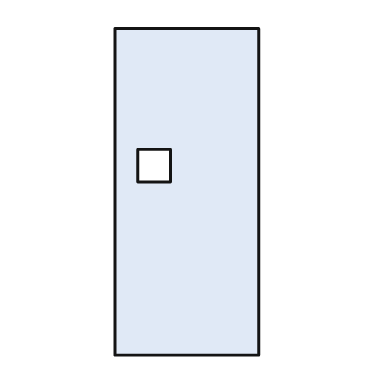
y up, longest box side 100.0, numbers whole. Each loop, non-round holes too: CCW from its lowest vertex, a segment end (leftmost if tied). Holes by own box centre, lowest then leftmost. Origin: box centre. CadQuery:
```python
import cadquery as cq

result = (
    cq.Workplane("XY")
    .moveTo(-22.0, -50.0)
    .lineTo(22.0, -50.0)
    .lineTo(22.0, 50.0)
    .lineTo(-22.0, 50.0)
    .close()
    .moveTo(-15.0, 3.0)
    .lineTo(-5.0, 3.0)
    .lineTo(-5.0, 13.0)
    .lineTo(-15.0, 13.0)
    .close()
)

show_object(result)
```